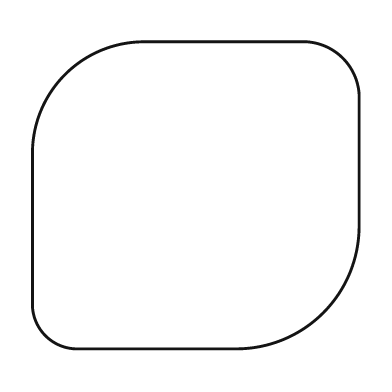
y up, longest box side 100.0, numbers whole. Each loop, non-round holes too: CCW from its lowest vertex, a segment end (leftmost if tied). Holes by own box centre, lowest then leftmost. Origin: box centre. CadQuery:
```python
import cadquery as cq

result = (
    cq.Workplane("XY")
    .moveTo(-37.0, -47.0)
    .lineTo(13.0, -47.0)
    .threePointArc((39.0, -36.0), (50.0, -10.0))
    .lineTo(50.0, 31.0)
    .threePointArc((45.0, 42.0), (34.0, 47.0))
    .lineTo(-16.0, 47.0)
    .threePointArc((-40.0, 37.0), (-50.0, 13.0))
    .lineTo(-50.0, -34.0)
    .threePointArc((-46.0, -43.0), (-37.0, -47.0))
    .close()
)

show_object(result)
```